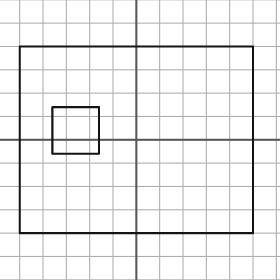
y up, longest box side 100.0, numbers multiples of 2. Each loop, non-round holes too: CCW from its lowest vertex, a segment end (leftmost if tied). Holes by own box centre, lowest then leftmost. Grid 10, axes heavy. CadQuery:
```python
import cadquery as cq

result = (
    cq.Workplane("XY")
    .moveTo(-50.0, -40.0)
    .lineTo(50.0, -40.0)
    .lineTo(50.0, 40.0)
    .lineTo(-50.0, 40.0)
    .close()
    .moveTo(-36.0, -6.0)
    .lineTo(-16.0, -6.0)
    .lineTo(-16.0, 14.0)
    .lineTo(-36.0, 14.0)
    .close()
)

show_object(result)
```